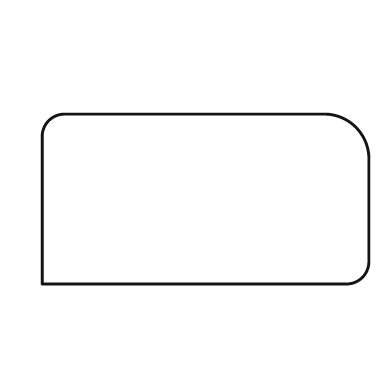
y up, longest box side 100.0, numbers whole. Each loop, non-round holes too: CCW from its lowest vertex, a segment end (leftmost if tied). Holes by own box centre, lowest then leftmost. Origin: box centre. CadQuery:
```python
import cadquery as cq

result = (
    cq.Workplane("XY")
    .moveTo(-50.0, -26.0)
    .lineTo(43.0, -26.0)
    .threePointArc((48.0, -24.0), (50.0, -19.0))
    .lineTo(50.0, 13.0)
    .threePointArc((46.0, 22.0), (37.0, 26.0))
    .lineTo(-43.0, 26.0)
    .threePointArc((-48.0, 24.0), (-50.0, 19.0))
    .close()
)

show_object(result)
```